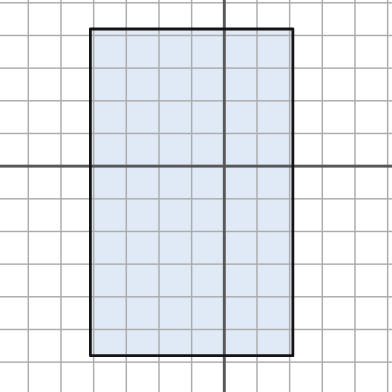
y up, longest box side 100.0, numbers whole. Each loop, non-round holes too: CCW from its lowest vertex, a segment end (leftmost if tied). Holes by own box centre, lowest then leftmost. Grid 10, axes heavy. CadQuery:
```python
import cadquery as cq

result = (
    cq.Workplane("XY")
    .moveTo(-41.0, -58.0)
    .lineTo(21.0, -58.0)
    .lineTo(21.0, 42.0)
    .lineTo(-41.0, 42.0)
    .close()
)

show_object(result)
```